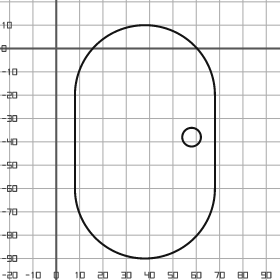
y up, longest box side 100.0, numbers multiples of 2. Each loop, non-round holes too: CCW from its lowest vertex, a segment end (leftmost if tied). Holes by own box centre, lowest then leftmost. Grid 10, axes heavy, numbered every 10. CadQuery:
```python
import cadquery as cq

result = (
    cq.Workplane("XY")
    .moveTo(8.0, -60.0)
    .threePointArc((38.0, -90.0), (68.0, -60.0))
    .lineTo(68.0, -20.0)
    .threePointArc((38.0, 10.0), (8.0, -20.0))
    .close()
    .moveTo(58.0, -38.0)
    .circle(4.0)
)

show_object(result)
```